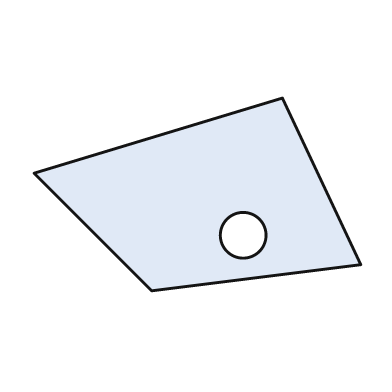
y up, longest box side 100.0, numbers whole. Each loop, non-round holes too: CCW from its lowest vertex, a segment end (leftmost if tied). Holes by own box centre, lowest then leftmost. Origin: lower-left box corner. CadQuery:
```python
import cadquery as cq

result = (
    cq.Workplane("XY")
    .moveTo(36.0, 0.0)
    .lineTo(100.0, 8.0)
    .lineTo(76.0, 59.0)
    .lineTo(0.0, 36.0)
    .close()
    .moveTo(64.0, 17.0)
    .circle(7.0)
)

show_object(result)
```